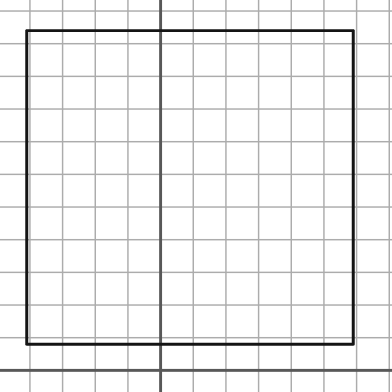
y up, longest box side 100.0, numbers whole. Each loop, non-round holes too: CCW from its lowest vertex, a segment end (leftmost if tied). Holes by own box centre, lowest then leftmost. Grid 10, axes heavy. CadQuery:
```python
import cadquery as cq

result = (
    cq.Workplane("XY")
    .moveTo(-41.0, 8.0)
    .lineTo(59.0, 8.0)
    .lineTo(59.0, 104.0)
    .lineTo(-41.0, 104.0)
    .close()
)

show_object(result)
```